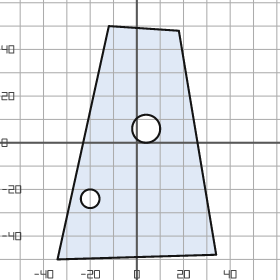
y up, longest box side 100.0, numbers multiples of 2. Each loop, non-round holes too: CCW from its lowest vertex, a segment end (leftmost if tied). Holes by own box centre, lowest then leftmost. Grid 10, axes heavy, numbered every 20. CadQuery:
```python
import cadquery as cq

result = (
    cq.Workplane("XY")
    .moveTo(-34.0, -50.0)
    .lineTo(34.0, -48.0)
    .lineTo(18.0, 48.0)
    .lineTo(-12.0, 50.0)
    .close()
    .moveTo(-20.0, -24.0)
    .circle(4.0)
    .moveTo(4.0, 6.0)
    .circle(6.0)
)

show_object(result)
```